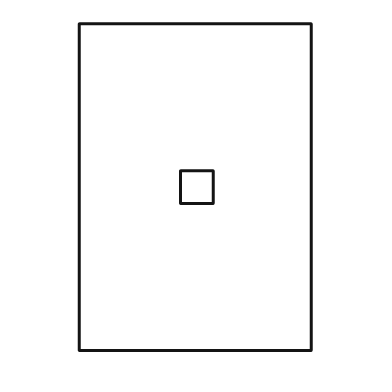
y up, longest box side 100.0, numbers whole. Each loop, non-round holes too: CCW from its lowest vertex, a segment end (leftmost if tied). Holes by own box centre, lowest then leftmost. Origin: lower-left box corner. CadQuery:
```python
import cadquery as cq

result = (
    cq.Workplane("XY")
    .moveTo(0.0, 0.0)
    .lineTo(71.0, 0.0)
    .lineTo(71.0, 100.0)
    .lineTo(0.0, 100.0)
    .close()
    .moveTo(31.0, 45.0)
    .lineTo(41.0, 45.0)
    .lineTo(41.0, 55.0)
    .lineTo(31.0, 55.0)
    .close()
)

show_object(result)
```